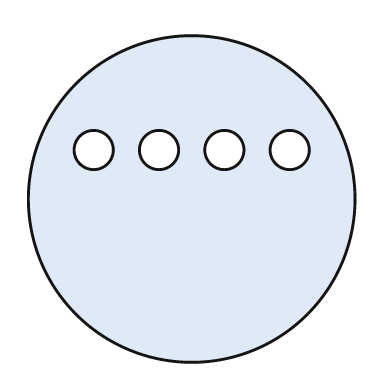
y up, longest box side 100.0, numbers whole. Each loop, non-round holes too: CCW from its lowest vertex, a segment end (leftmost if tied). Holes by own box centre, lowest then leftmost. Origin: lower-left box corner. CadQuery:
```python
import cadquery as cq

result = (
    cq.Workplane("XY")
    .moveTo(50.0, 50.0)
    .circle(50.0)
    .moveTo(20.0, 65.0)
    .circle(6.0)
    .moveTo(40.0, 65.0)
    .circle(6.0)
    .moveTo(60.0, 65.0)
    .circle(6.0)
    .moveTo(80.0, 65.0)
    .circle(6.0)
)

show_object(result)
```